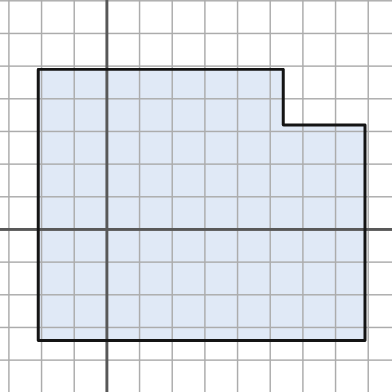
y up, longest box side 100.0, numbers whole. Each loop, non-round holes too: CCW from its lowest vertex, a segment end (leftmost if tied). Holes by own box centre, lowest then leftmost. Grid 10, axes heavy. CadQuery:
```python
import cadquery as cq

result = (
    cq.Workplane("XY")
    .moveTo(-21.0, -34.0)
    .lineTo(79.0, -34.0)
    .lineTo(79.0, 32.0)
    .lineTo(54.0, 32.0)
    .lineTo(54.0, 49.0)
    .lineTo(-21.0, 49.0)
    .close()
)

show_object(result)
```